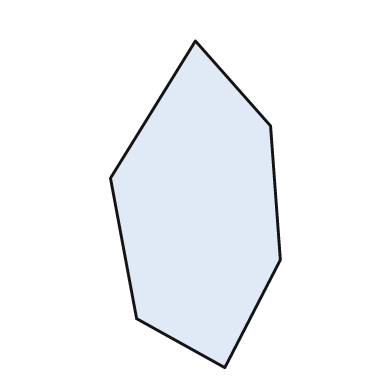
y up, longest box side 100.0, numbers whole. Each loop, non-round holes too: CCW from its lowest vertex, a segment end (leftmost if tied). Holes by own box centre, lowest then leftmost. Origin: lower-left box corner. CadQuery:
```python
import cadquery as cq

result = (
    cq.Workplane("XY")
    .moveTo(35.0, 0.0)
    .lineTo(52.0, 33.0)
    .lineTo(49.0, 74.0)
    .lineTo(26.0, 100.0)
    .lineTo(0.0, 58.0)
    .lineTo(8.0, 15.0)
    .close()
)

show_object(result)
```